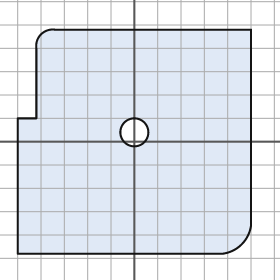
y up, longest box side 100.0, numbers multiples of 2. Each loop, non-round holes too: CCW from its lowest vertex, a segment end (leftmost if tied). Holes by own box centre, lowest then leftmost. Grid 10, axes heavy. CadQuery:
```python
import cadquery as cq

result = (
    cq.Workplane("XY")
    .moveTo(-50.0, -48.0)
    .lineTo(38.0, -48.0)
    .threePointArc((46.0, -44.0), (50.0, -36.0))
    .lineTo(50.0, 48.0)
    .lineTo(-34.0, 48.0)
    .threePointArc((-40.0, 46.0), (-42.0, 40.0))
    .lineTo(-42.0, 10.0)
    .lineTo(-50.0, 10.0)
    .close()
    .moveTo(0.0, 4.0)
    .circle(6.0)
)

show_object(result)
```